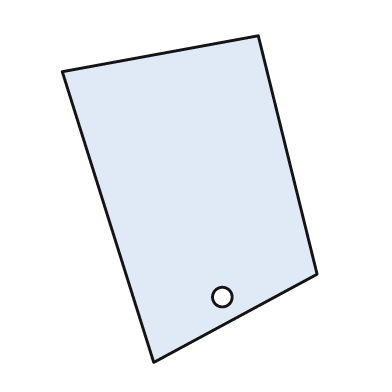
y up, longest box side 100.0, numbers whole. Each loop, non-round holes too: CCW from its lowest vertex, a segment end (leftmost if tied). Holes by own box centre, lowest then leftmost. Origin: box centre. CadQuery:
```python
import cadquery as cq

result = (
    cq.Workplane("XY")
    .moveTo(-11.0, -50.0)
    .lineTo(39.0, -23.0)
    .lineTo(21.0, 50.0)
    .lineTo(-39.0, 39.0)
    .close()
    .moveTo(10.0, -30.0)
    .circle(3.0)
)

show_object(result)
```